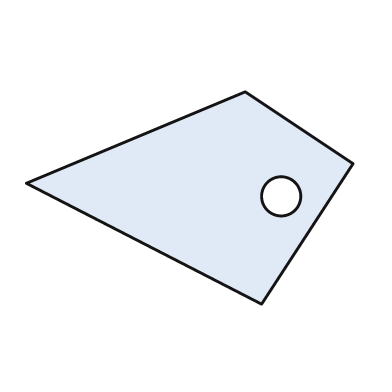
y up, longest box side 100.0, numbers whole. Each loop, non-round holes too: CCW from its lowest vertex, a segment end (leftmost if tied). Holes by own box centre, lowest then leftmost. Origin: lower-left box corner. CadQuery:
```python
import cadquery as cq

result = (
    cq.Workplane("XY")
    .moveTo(72.0, 0.0)
    .lineTo(100.0, 43.0)
    .lineTo(67.0, 65.0)
    .lineTo(0.0, 37.0)
    .close()
    .moveTo(78.0, 33.0)
    .circle(6.0)
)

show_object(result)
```